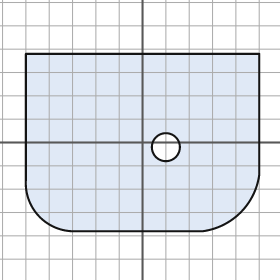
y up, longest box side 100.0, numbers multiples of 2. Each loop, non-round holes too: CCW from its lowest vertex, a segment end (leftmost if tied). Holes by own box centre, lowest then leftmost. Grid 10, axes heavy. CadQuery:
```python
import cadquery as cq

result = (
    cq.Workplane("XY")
    .moveTo(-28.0, -38.0)
    .lineTo(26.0, -38.0)
    .threePointArc((42.0, -30.0), (50.0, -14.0))
    .lineTo(50.0, 38.0)
    .lineTo(-50.0, 38.0)
    .lineTo(-50.0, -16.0)
    .threePointArc((-44.0, -32.0), (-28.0, -38.0))
    .close()
    .moveTo(10.0, -2.0)
    .circle(6.0)
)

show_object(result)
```